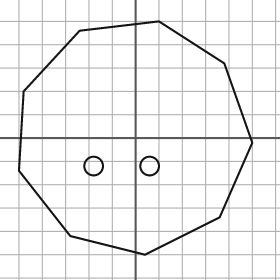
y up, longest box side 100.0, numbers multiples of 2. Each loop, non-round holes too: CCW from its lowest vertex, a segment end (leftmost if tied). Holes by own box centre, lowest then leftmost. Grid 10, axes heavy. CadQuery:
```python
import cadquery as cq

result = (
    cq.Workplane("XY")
    .moveTo(4.0, -50.0)
    .lineTo(36.0, -34.0)
    .lineTo(50.0, -2.0)
    .lineTo(38.0, 32.0)
    .lineTo(10.0, 50.0)
    .lineTo(-24.0, 46.0)
    .lineTo(-48.0, 20.0)
    .lineTo(-50.0, -14.0)
    .lineTo(-28.0, -42.0)
    .close()
    .moveTo(-18.0, -12.0)
    .circle(4.0)
    .moveTo(6.0, -12.0)
    .circle(4.0)
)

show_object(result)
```